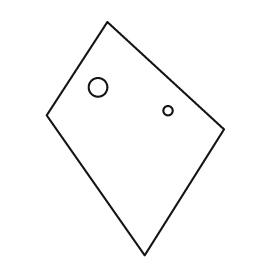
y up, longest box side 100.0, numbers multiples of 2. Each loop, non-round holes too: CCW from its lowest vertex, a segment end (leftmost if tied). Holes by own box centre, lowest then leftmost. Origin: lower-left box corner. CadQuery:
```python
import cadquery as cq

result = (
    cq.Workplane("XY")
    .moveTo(42.0, 0.0)
    .lineTo(76.0, 54.0)
    .lineTo(26.0, 100.0)
    .lineTo(0.0, 60.0)
    .close()
    .moveTo(52.0, 62.0)
    .circle(2.0)
    .moveTo(22.0, 72.0)
    .circle(4.0)
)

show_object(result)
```